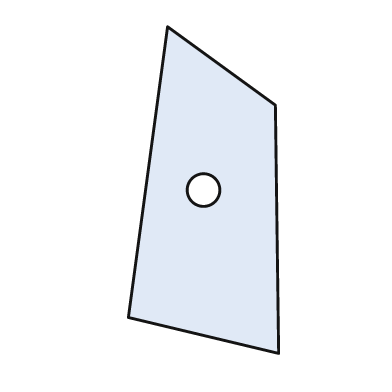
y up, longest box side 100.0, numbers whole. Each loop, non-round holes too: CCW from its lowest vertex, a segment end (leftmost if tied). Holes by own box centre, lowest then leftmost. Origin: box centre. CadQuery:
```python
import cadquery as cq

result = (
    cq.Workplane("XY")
    .moveTo(23.0, -50.0)
    .lineTo(22.0, 26.0)
    .lineTo(-11.0, 50.0)
    .lineTo(-23.0, -39.0)
    .close()
    .moveTo(0.0, 0.0)
    .circle(5.0)
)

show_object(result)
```